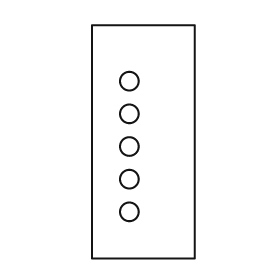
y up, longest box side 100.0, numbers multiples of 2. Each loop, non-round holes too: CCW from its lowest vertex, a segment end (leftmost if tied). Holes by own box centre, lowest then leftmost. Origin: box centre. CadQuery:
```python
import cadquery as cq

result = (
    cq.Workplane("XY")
    .moveTo(-22.0, -50.0)
    .lineTo(22.0, -50.0)
    .lineTo(22.0, 50.0)
    .lineTo(-22.0, 50.0)
    .close()
    .moveTo(-6.0, -30.0)
    .circle(4.0)
    .moveTo(-6.0, -16.0)
    .circle(4.0)
    .moveTo(-6.0, -2.0)
    .circle(4.0)
    .moveTo(-6.0, 12.0)
    .circle(4.0)
    .moveTo(-6.0, 26.0)
    .circle(4.0)
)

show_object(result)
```